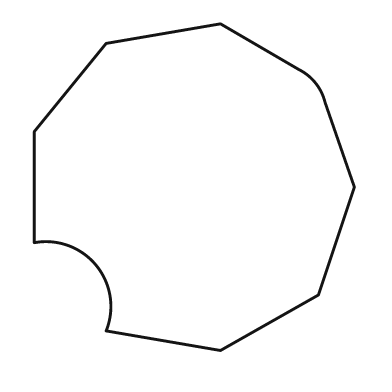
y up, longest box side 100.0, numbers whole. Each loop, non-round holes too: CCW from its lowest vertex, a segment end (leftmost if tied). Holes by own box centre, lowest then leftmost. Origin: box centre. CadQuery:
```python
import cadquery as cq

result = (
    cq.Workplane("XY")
    .moveTo(8.0, -50.0)
    .lineTo(38.0, -33.0)
    .lineTo(49.0, 0.0)
    .lineTo(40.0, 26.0)
    .threePointArc((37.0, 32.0), (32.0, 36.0))
    .lineTo(8.0, 50.0)
    .lineTo(-27.0, 44.0)
    .lineTo(-49.0, 17.0)
    .lineTo(-49.0, -17.0)
    .threePointArc((-30.0, -24.0), (-27.0, -44.0))
    .close()
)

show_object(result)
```